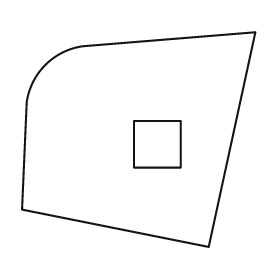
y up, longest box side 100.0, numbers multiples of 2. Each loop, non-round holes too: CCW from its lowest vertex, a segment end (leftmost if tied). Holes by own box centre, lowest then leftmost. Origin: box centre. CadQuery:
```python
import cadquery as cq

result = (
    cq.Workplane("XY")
    .moveTo(30.0, -46.0)
    .lineTo(50.0, 46.0)
    .lineTo(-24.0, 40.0)
    .threePointArc((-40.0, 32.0), (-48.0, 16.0))
    .lineTo(-50.0, -30.0)
    .close()
    .moveTo(-2.0, -12.0)
    .lineTo(18.0, -12.0)
    .lineTo(18.0, 8.0)
    .lineTo(-2.0, 8.0)
    .close()
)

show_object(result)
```